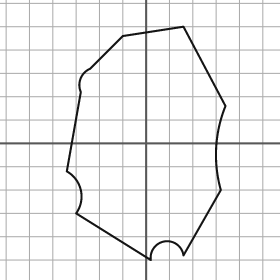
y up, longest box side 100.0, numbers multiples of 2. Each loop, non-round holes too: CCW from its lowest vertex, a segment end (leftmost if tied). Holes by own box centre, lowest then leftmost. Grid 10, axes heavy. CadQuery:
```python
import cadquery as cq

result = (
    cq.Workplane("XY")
    .moveTo(2.0, -50.0)
    .threePointArc((8.0, -42.0), (16.0, -48.0))
    .lineTo(32.0, -20.0)
    .threePointArc((30.0, -2.0), (34.0, 16.0))
    .lineTo(16.0, 50.0)
    .lineTo(-10.0, 46.0)
    .lineTo(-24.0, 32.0)
    .threePointArc((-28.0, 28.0), (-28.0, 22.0))
    .lineTo(-34.0, -12.0)
    .threePointArc((-28.0, -20.0), (-30.0, -30.0))
    .close()
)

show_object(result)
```